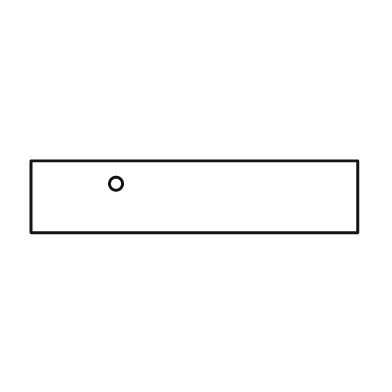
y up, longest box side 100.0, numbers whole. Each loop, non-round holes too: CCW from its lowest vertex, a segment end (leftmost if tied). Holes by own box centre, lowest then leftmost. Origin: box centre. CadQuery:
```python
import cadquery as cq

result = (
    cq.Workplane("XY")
    .moveTo(-50.0, -11.0)
    .lineTo(50.0, -11.0)
    .lineTo(50.0, 11.0)
    .lineTo(-50.0, 11.0)
    .close()
    .moveTo(-24.0, 4.0)
    .circle(2.0)
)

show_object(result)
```